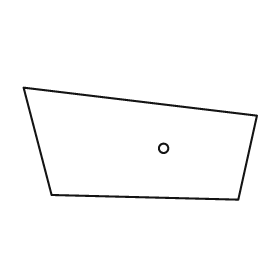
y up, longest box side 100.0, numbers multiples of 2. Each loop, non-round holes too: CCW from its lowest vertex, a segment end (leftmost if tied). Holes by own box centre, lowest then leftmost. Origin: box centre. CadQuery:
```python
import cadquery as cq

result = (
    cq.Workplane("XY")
    .moveTo(42.0, -24.0)
    .lineTo(50.0, 12.0)
    .lineTo(-50.0, 24.0)
    .lineTo(-38.0, -22.0)
    .close()
    .moveTo(10.0, -2.0)
    .circle(2.0)
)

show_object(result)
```